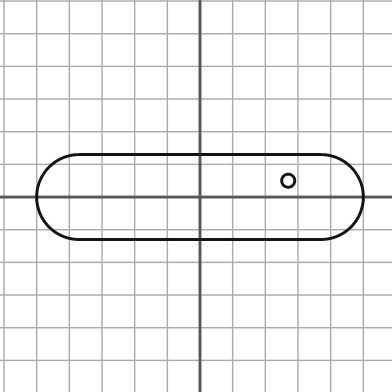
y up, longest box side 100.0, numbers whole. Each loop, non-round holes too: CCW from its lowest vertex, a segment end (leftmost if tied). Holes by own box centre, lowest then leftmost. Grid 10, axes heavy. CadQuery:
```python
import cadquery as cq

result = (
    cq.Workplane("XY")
    .moveTo(-37.0, -13.0)
    .lineTo(37.0, -13.0)
    .threePointArc((50.0, 0.0), (37.0, 13.0))
    .lineTo(-37.0, 13.0)
    .threePointArc((-50.0, 0.0), (-37.0, -13.0))
    .close()
    .moveTo(27.0, 5.0)
    .circle(2.0)
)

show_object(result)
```